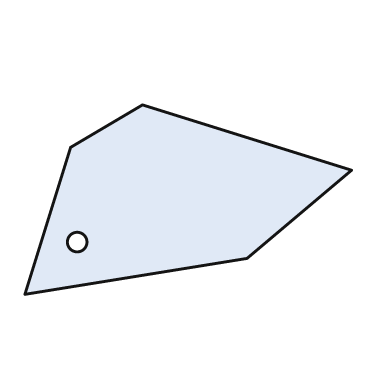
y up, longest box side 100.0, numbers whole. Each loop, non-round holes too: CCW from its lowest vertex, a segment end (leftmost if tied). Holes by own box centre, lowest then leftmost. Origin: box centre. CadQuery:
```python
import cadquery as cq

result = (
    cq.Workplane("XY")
    .moveTo(-50.0, -29.0)
    .lineTo(18.0, -18.0)
    .lineTo(50.0, 9.0)
    .lineTo(-14.0, 29.0)
    .lineTo(-36.0, 16.0)
    .close()
    .moveTo(-34.0, -13.0)
    .circle(3.0)
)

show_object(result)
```